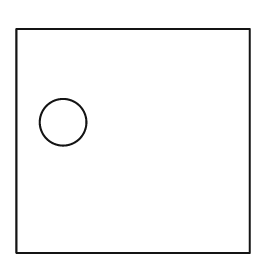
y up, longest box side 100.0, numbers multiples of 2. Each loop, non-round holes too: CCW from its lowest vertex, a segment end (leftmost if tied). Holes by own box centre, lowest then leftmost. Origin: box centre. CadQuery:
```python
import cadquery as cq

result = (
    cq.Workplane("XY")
    .moveTo(-50.0, -48.0)
    .lineTo(50.0, -48.0)
    .lineTo(50.0, 48.0)
    .lineTo(-50.0, 48.0)
    .close()
    .moveTo(-30.0, 8.0)
    .circle(10.0)
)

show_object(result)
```